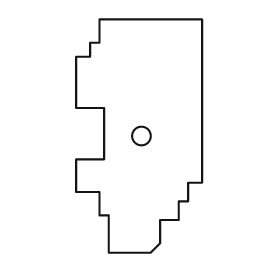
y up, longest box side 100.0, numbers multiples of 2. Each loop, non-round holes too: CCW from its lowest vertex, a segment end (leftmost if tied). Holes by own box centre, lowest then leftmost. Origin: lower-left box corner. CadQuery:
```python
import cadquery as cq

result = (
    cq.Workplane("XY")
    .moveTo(14.0, 0.0)
    .lineTo(32.0, 0.0)
    .lineTo(36.0, 4.0)
    .lineTo(36.0, 14.0)
    .lineTo(44.0, 14.0)
    .lineTo(44.0, 22.0)
    .lineTo(48.0, 22.0)
    .lineTo(48.0, 30.0)
    .lineTo(54.0, 30.0)
    .lineTo(54.0, 100.0)
    .lineTo(10.0, 100.0)
    .lineTo(10.0, 90.0)
    .lineTo(6.0, 90.0)
    .lineTo(6.0, 84.0)
    .lineTo(0.0, 84.0)
    .lineTo(0.0, 62.0)
    .lineTo(12.0, 62.0)
    .lineTo(12.0, 40.0)
    .lineTo(0.0, 40.0)
    .lineTo(0.0, 26.0)
    .lineTo(10.0, 26.0)
    .lineTo(10.0, 16.0)
    .lineTo(14.0, 16.0)
    .close()
    .moveTo(28.0, 50.0)
    .circle(4.0)
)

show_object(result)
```